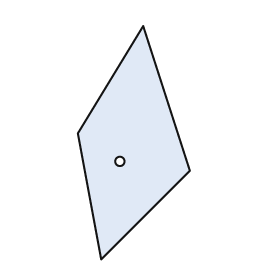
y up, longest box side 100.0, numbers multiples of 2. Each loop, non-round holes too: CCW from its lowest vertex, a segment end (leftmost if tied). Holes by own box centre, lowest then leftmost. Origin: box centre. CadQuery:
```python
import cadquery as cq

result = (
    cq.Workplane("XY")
    .moveTo(-14.0, -50.0)
    .lineTo(24.0, -12.0)
    .lineTo(4.0, 50.0)
    .lineTo(-24.0, 4.0)
    .close()
    .moveTo(-6.0, -8.0)
    .circle(2.0)
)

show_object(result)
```